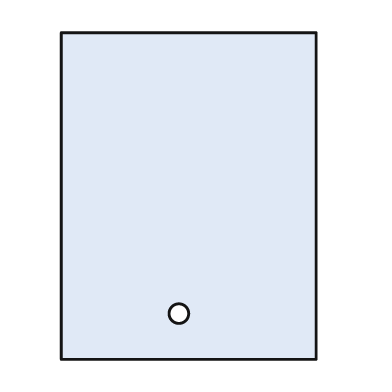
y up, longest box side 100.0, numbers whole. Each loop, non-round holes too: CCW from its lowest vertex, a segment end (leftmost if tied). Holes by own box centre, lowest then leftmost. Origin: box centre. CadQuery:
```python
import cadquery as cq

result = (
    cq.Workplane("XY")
    .moveTo(-39.0, -50.0)
    .lineTo(39.0, -50.0)
    .lineTo(39.0, 50.0)
    .lineTo(-39.0, 50.0)
    .close()
    .moveTo(-3.0, -36.0)
    .circle(3.0)
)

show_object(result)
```